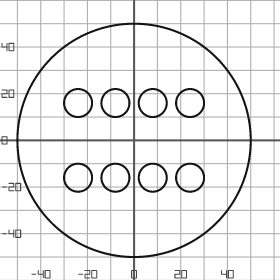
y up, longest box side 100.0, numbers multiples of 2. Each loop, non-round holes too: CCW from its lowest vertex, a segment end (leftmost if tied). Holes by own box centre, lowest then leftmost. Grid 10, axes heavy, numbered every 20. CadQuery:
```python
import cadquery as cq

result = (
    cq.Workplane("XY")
    .moveTo(0.0, 0.0)
    .circle(50.0)
    .moveTo(-24.0, -16.0)
    .circle(6.0)
    .moveTo(-8.0, -16.0)
    .circle(6.0)
    .moveTo(8.0, -16.0)
    .circle(6.0)
    .moveTo(24.0, -16.0)
    .circle(6.0)
    .moveTo(-24.0, 16.0)
    .circle(6.0)
    .moveTo(-8.0, 16.0)
    .circle(6.0)
    .moveTo(8.0, 16.0)
    .circle(6.0)
    .moveTo(24.0, 16.0)
    .circle(6.0)
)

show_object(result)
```